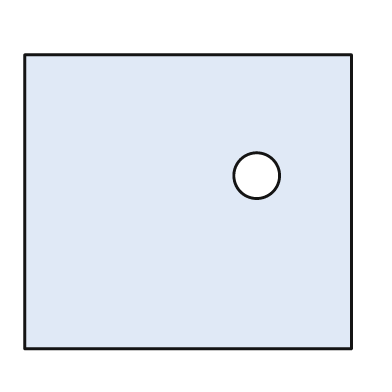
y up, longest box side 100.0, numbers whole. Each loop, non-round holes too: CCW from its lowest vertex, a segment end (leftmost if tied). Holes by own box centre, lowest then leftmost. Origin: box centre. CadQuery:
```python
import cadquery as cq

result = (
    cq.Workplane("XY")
    .moveTo(-50.0, -45.0)
    .lineTo(50.0, -45.0)
    .lineTo(50.0, 45.0)
    .lineTo(-50.0, 45.0)
    .close()
    .moveTo(21.0, 8.0)
    .circle(7.0)
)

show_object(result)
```